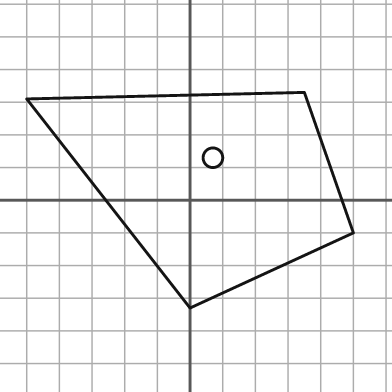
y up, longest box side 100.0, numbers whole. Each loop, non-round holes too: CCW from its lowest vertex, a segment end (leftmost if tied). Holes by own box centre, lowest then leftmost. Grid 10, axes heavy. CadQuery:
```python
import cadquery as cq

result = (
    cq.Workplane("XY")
    .moveTo(0.0, -33.0)
    .lineTo(50.0, -10.0)
    .lineTo(35.0, 33.0)
    .lineTo(-50.0, 31.0)
    .close()
    .moveTo(7.0, 13.0)
    .circle(3.0)
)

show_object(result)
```